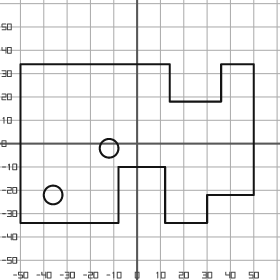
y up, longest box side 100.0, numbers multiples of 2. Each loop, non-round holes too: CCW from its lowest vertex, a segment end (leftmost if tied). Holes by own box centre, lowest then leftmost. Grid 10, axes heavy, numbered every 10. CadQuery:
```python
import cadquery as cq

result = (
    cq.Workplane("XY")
    .moveTo(-50.0, -34.0)
    .lineTo(-8.0, -34.0)
    .lineTo(-8.0, -10.0)
    .lineTo(12.0, -10.0)
    .lineTo(12.0, -34.0)
    .lineTo(30.0, -34.0)
    .lineTo(30.0, -22.0)
    .lineTo(50.0, -22.0)
    .lineTo(50.0, 34.0)
    .lineTo(36.0, 34.0)
    .lineTo(36.0, 18.0)
    .lineTo(14.0, 18.0)
    .lineTo(14.0, 34.0)
    .lineTo(-50.0, 34.0)
    .close()
    .moveTo(-36.0, -22.0)
    .circle(4.0)
    .moveTo(-12.0, -2.0)
    .circle(4.0)
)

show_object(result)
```